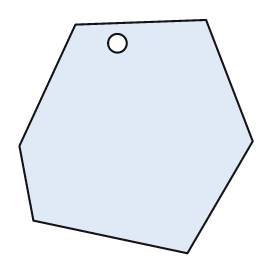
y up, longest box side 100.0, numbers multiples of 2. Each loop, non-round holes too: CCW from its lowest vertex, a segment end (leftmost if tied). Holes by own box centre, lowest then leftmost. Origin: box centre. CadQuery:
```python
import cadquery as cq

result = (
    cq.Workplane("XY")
    .moveTo(22.0, -50.0)
    .lineTo(50.0, -2.0)
    .lineTo(30.0, 50.0)
    .lineTo(-26.0, 48.0)
    .lineTo(-50.0, -4.0)
    .lineTo(-44.0, -36.0)
    .close()
    .moveTo(-8.0, 40.0)
    .circle(4.0)
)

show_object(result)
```